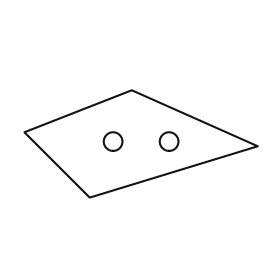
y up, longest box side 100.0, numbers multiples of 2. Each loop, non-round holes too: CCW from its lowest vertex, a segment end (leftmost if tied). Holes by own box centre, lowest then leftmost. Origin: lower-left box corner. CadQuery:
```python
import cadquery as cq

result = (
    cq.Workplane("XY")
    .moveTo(28.0, 0.0)
    .lineTo(100.0, 22.0)
    .lineTo(46.0, 46.0)
    .lineTo(0.0, 28.0)
    .close()
    .moveTo(38.0, 24.0)
    .circle(4.0)
    .moveTo(62.0, 24.0)
    .circle(4.0)
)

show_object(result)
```